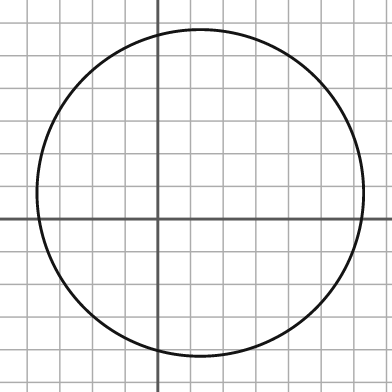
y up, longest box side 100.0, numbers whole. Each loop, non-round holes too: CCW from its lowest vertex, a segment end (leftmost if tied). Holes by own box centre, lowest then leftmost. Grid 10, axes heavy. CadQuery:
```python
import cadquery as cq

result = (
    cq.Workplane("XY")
    .moveTo(13.0, 8.0)
    .circle(50.0)
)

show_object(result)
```